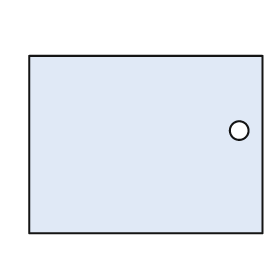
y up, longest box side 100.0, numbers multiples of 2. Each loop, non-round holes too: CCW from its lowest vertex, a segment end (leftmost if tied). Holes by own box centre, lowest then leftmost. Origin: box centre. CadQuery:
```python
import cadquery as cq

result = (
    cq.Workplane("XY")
    .moveTo(-50.0, -38.0)
    .lineTo(50.0, -38.0)
    .lineTo(50.0, 38.0)
    .lineTo(-50.0, 38.0)
    .close()
    .moveTo(40.0, 6.0)
    .circle(4.0)
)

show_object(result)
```